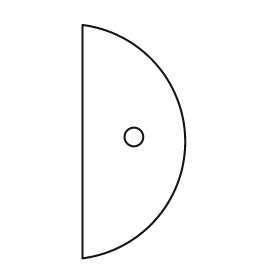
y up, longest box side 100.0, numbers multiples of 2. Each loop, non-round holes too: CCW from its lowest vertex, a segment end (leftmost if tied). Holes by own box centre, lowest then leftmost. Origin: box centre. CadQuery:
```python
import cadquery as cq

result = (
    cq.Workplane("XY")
    .moveTo(-22.0, -50.0)
    .threePointArc((22.0, 0.0), (-22.0, 50.0))
    .close()
    .moveTo(0.0, 2.0)
    .circle(4.0)
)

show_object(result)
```